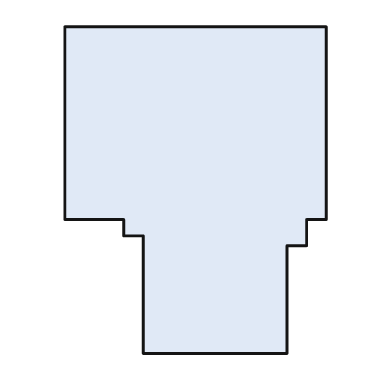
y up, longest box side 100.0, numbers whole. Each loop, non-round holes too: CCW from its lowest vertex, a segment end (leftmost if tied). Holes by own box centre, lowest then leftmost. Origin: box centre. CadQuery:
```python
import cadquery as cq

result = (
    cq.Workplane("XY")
    .moveTo(-16.0, -50.0)
    .lineTo(28.0, -50.0)
    .lineTo(28.0, -17.0)
    .lineTo(34.0, -17.0)
    .lineTo(34.0, -9.0)
    .lineTo(40.0, -9.0)
    .lineTo(40.0, 50.0)
    .lineTo(-40.0, 50.0)
    .lineTo(-40.0, -9.0)
    .lineTo(-22.0, -9.0)
    .lineTo(-22.0, -14.0)
    .lineTo(-16.0, -14.0)
    .close()
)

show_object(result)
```